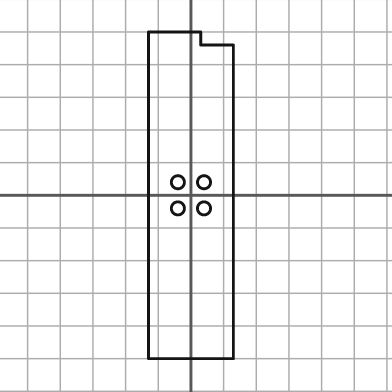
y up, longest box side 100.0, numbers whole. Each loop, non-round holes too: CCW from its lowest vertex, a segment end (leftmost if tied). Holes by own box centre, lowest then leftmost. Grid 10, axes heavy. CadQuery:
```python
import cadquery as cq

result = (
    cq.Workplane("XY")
    .moveTo(-13.0, -50.0)
    .lineTo(13.0, -50.0)
    .lineTo(13.0, 46.0)
    .lineTo(3.0, 46.0)
    .lineTo(3.0, 50.0)
    .lineTo(-13.0, 50.0)
    .close()
    .moveTo(-4.0, -4.0)
    .circle(2.0)
    .moveTo(4.0, -4.0)
    .circle(2.0)
    .moveTo(-4.0, 4.0)
    .circle(2.0)
    .moveTo(4.0, 4.0)
    .circle(2.0)
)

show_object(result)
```